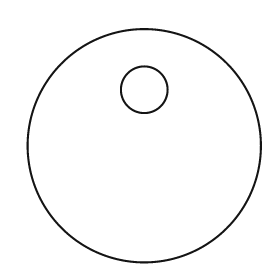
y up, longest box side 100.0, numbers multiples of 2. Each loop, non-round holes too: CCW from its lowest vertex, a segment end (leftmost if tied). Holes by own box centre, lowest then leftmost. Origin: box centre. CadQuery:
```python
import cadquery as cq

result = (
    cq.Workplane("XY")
    .moveTo(0.0, 0.0)
    .circle(50.0)
    .moveTo(0.0, 24.0)
    .circle(10.0)
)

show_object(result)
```